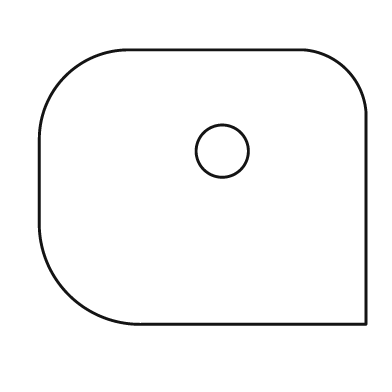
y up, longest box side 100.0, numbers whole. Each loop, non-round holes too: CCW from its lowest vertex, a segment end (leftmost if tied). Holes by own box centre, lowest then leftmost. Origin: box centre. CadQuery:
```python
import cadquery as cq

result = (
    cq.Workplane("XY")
    .moveTo(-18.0, -42.0)
    .lineTo(50.0, -42.0)
    .lineTo(50.0, 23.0)
    .threePointArc((44.0, 36.0), (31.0, 42.0))
    .lineTo(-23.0, 42.0)
    .threePointArc((-42.0, 34.0), (-50.0, 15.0))
    .lineTo(-50.0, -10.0)
    .threePointArc((-41.0, -33.0), (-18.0, -42.0))
    .close()
    .moveTo(6.0, 11.0)
    .circle(8.0)
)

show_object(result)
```